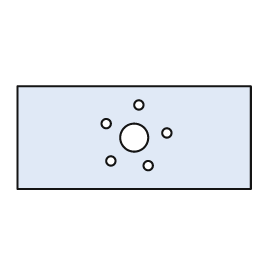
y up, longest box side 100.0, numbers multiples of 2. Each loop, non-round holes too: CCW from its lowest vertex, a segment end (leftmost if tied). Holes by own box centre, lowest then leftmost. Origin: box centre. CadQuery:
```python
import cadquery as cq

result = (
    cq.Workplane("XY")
    .moveTo(-50.0, -22.0)
    .lineTo(50.0, -22.0)
    .lineTo(50.0, 22.0)
    .lineTo(-50.0, 22.0)
    .close()
    .moveTo(6.0, -12.0)
    .circle(2.0)
    .moveTo(-10.0, -10.0)
    .circle(2.0)
    .moveTo(0.0, 0.0)
    .circle(6.0)
    .moveTo(14.0, 2.0)
    .circle(2.0)
    .moveTo(-12.0, 6.0)
    .circle(2.0)
    .moveTo(2.0, 14.0)
    .circle(2.0)
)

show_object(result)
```